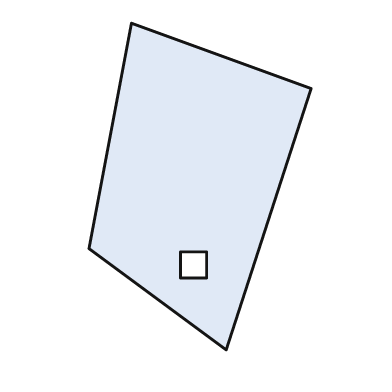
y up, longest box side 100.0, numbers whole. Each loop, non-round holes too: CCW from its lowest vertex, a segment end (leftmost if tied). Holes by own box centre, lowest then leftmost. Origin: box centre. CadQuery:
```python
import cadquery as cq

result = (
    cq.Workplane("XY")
    .moveTo(8.0, -50.0)
    .lineTo(34.0, 30.0)
    .lineTo(-21.0, 50.0)
    .lineTo(-34.0, -19.0)
    .close()
    .moveTo(-6.0, -28.0)
    .lineTo(2.0, -28.0)
    .lineTo(2.0, -20.0)
    .lineTo(-6.0, -20.0)
    .close()
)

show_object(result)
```